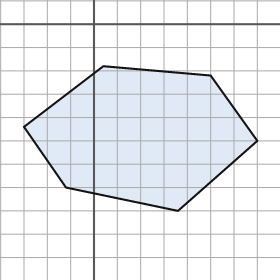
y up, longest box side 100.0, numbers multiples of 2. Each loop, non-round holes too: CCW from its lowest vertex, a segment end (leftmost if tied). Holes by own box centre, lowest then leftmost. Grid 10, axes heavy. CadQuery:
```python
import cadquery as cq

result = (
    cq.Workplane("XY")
    .moveTo(36.0, -80.0)
    .lineTo(70.0, -50.0)
    .lineTo(50.0, -22.0)
    .lineTo(4.0, -18.0)
    .lineTo(-30.0, -44.0)
    .lineTo(-12.0, -70.0)
    .close()
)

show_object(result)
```